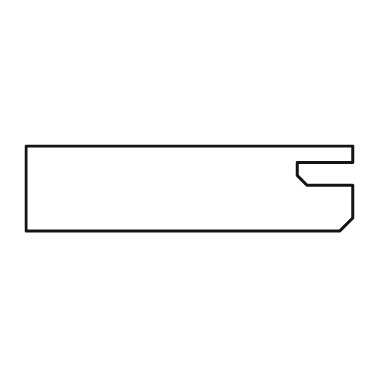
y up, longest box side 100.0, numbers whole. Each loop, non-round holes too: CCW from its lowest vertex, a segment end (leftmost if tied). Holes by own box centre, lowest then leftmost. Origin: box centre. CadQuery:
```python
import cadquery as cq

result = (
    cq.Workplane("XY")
    .moveTo(-50.0, -13.0)
    .lineTo(46.0, -13.0)
    .lineTo(50.0, -9.0)
    .lineTo(50.0, 1.0)
    .lineTo(36.0, 1.0)
    .lineTo(33.0, 4.0)
    .lineTo(33.0, 8.0)
    .lineTo(50.0, 8.0)
    .lineTo(50.0, 13.0)
    .lineTo(-50.0, 13.0)
    .close()
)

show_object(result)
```